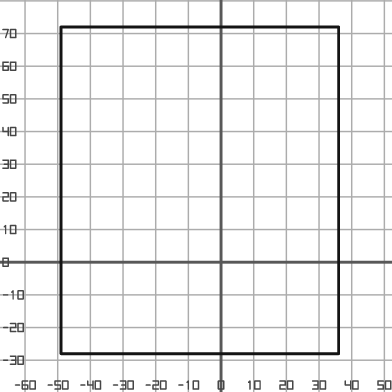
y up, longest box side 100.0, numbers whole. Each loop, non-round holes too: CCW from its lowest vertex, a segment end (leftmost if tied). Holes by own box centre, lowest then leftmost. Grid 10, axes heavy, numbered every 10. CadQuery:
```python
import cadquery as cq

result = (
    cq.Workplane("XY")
    .moveTo(-49.0, -28.0)
    .lineTo(36.0, -28.0)
    .lineTo(36.0, 72.0)
    .lineTo(-49.0, 72.0)
    .close()
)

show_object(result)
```